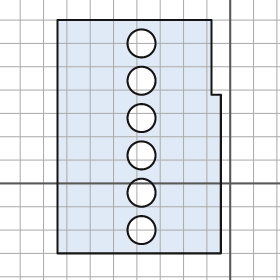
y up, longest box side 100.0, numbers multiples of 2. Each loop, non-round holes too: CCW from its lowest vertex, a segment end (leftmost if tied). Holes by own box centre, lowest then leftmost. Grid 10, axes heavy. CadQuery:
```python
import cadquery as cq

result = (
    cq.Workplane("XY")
    .moveTo(-74.0, -30.0)
    .lineTo(-4.0, -30.0)
    .lineTo(-4.0, 38.0)
    .lineTo(-8.0, 38.0)
    .lineTo(-8.0, 70.0)
    .lineTo(-74.0, 70.0)
    .close()
    .moveTo(-38.0, -20.0)
    .circle(6.0)
    .moveTo(-38.0, -4.0)
    .circle(6.0)
    .moveTo(-38.0, 12.0)
    .circle(6.0)
    .moveTo(-38.0, 28.0)
    .circle(6.0)
    .moveTo(-38.0, 44.0)
    .circle(6.0)
    .moveTo(-38.0, 60.0)
    .circle(6.0)
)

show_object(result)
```